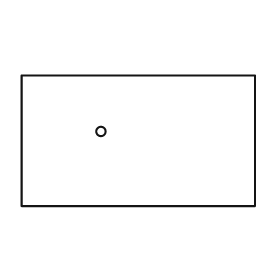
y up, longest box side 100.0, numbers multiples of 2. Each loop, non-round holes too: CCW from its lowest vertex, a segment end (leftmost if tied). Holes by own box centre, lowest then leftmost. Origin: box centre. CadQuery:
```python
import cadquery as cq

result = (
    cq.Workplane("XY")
    .moveTo(-50.0, -28.0)
    .lineTo(50.0, -28.0)
    .lineTo(50.0, 28.0)
    .lineTo(-50.0, 28.0)
    .close()
    .moveTo(-16.0, 4.0)
    .circle(2.0)
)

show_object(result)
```